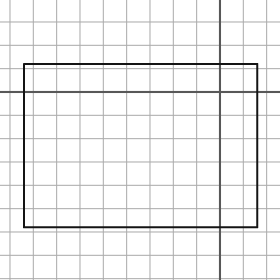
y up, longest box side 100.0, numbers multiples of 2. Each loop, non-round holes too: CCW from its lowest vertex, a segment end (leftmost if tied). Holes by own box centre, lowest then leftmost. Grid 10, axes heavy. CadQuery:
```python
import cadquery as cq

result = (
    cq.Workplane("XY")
    .moveTo(-84.0, -58.0)
    .lineTo(16.0, -58.0)
    .lineTo(16.0, 12.0)
    .lineTo(-84.0, 12.0)
    .close()
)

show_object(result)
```